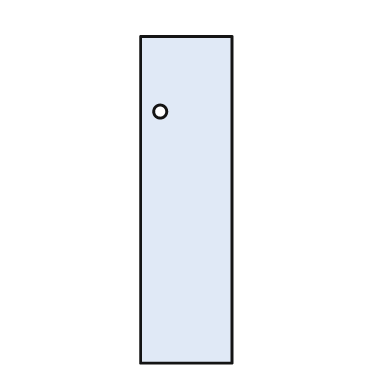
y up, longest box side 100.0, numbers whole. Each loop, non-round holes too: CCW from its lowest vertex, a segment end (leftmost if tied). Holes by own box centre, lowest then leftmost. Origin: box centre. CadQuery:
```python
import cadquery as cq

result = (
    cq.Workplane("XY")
    .moveTo(-14.0, -50.0)
    .lineTo(14.0, -50.0)
    .lineTo(14.0, 50.0)
    .lineTo(-14.0, 50.0)
    .close()
    .moveTo(-8.0, 27.0)
    .circle(2.0)
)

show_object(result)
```